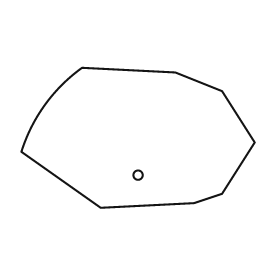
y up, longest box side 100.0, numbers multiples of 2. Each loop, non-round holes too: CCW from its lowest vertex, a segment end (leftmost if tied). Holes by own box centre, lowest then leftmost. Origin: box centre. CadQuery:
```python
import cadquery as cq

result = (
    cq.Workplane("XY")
    .moveTo(-16.0, -30.0)
    .lineTo(24.0, -28.0)
    .lineTo(36.0, -24.0)
    .lineTo(50.0, -2.0)
    .lineTo(36.0, 20.0)
    .lineTo(16.0, 28.0)
    .lineTo(-24.0, 30.0)
    .threePointArc((-40.0, 14.0), (-50.0, -6.0))
    .close()
    .moveTo(0.0, -16.0)
    .circle(2.0)
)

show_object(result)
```